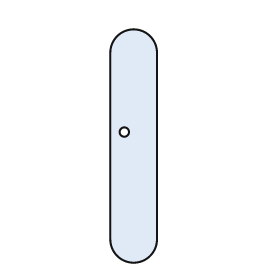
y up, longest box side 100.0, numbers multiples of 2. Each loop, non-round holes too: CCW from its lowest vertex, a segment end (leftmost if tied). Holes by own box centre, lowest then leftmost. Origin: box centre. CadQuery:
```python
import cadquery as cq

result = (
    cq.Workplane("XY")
    .moveTo(-10.0, -40.0)
    .threePointArc((0.0, -50.0), (10.0, -40.0))
    .lineTo(10.0, 40.0)
    .threePointArc((0.0, 50.0), (-10.0, 40.0))
    .close()
    .moveTo(-4.0, 6.0)
    .circle(2.0)
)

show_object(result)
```